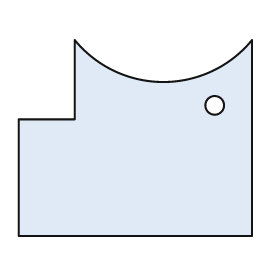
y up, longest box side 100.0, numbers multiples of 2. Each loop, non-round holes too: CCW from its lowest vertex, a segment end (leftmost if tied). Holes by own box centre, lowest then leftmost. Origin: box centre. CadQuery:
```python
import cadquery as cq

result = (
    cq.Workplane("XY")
    .moveTo(-50.0, -42.0)
    .lineTo(50.0, -42.0)
    .lineTo(50.0, 42.0)
    .threePointArc((12.0, 24.0), (-26.0, 42.0))
    .lineTo(-26.0, 8.0)
    .lineTo(-50.0, 8.0)
    .close()
    .moveTo(34.0, 14.0)
    .circle(4.0)
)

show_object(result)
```